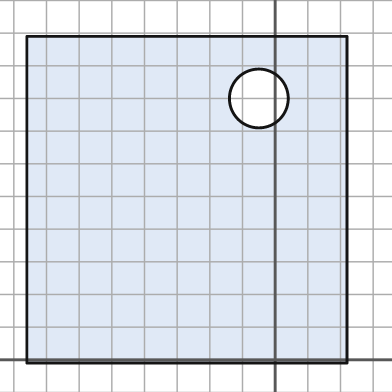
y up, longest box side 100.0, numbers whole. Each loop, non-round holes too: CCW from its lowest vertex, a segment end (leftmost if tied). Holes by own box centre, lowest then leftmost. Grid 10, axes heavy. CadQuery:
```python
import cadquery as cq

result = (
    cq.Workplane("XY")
    .moveTo(-76.0, -1.0)
    .lineTo(22.0, -1.0)
    .lineTo(22.0, 99.0)
    .lineTo(-76.0, 99.0)
    .close()
    .moveTo(-5.0, 80.0)
    .circle(9.0)
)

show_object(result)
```